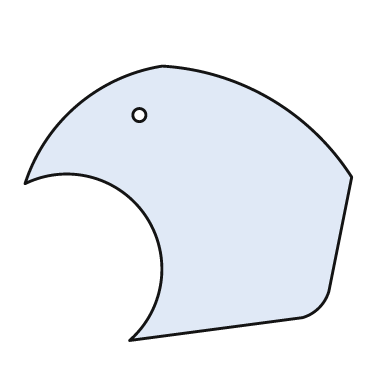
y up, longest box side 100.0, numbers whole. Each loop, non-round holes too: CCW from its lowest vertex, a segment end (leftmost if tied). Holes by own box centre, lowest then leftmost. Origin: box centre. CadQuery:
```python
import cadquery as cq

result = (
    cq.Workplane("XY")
    .moveTo(-18.0, -42.0)
    .lineTo(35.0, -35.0)
    .threePointArc((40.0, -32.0), (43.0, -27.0))
    .lineTo(50.0, 8.0)
    .threePointArc((25.0, 32.0), (-8.0, 42.0))
    .threePointArc((-34.0, 30.0), (-50.0, 6.0))
    .threePointArc((-13.0, -4.0), (-18.0, -42.0))
    .close()
    .moveTo(-15.0, 27.0)
    .circle(2.0)
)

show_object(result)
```